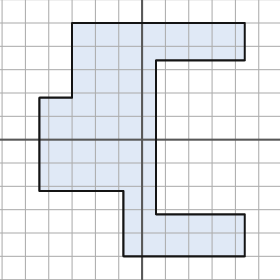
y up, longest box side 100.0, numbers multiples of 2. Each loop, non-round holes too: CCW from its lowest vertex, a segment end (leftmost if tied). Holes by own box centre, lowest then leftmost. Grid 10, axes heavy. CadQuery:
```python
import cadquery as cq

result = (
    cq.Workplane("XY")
    .moveTo(-8.0, -50.0)
    .lineTo(44.0, -50.0)
    .lineTo(44.0, -32.0)
    .lineTo(6.0, -32.0)
    .lineTo(6.0, 34.0)
    .lineTo(44.0, 34.0)
    .lineTo(44.0, 50.0)
    .lineTo(-30.0, 50.0)
    .lineTo(-30.0, 18.0)
    .lineTo(-44.0, 18.0)
    .lineTo(-44.0, -22.0)
    .lineTo(-8.0, -22.0)
    .close()
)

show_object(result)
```